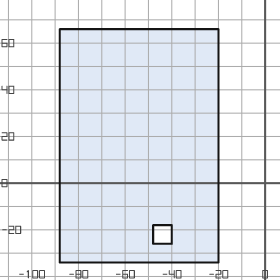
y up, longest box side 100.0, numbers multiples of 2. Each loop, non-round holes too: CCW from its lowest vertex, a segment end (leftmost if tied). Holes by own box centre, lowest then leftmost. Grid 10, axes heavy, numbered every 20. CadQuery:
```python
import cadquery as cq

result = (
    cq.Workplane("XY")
    .moveTo(-88.0, -34.0)
    .lineTo(-20.0, -34.0)
    .lineTo(-20.0, 66.0)
    .lineTo(-88.0, 66.0)
    .close()
    .moveTo(-48.0, -26.0)
    .lineTo(-40.0, -26.0)
    .lineTo(-40.0, -18.0)
    .lineTo(-48.0, -18.0)
    .close()
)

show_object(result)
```